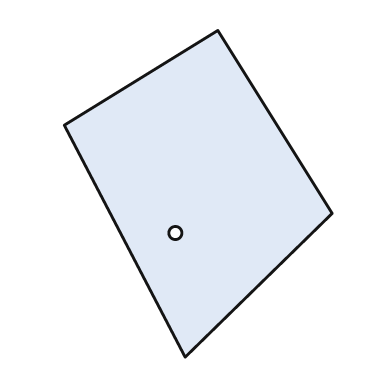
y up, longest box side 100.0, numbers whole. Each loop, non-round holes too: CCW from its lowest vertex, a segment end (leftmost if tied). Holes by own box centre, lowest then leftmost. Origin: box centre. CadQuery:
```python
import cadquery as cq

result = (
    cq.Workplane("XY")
    .moveTo(-4.0, -50.0)
    .lineTo(41.0, -6.0)
    .lineTo(6.0, 50.0)
    .lineTo(-41.0, 21.0)
    .close()
    .moveTo(-7.0, -12.0)
    .circle(2.0)
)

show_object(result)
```